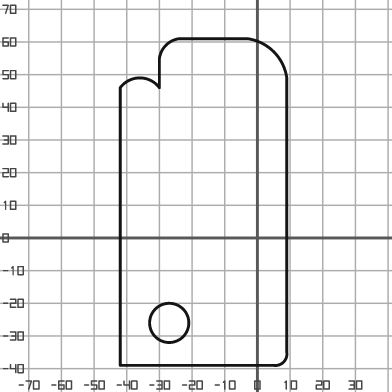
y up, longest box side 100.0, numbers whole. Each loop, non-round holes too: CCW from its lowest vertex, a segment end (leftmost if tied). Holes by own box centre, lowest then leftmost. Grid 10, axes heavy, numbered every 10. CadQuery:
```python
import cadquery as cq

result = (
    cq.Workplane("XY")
    .moveTo(-42.0, -39.0)
    .lineTo(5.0, -39.0)
    .threePointArc((8.0, -38.0), (9.0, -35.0))
    .lineTo(9.0, 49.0)
    .threePointArc((5.0, 57.0), (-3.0, 61.0))
    .lineTo(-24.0, 61.0)
    .threePointArc((-28.0, 59.0), (-30.0, 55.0))
    .lineTo(-30.0, 46.0)
    .threePointArc((-36.0, 49.0), (-42.0, 46.0))
    .close()
    .moveTo(-27.0, -26.0)
    .circle(6.0)
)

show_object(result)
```